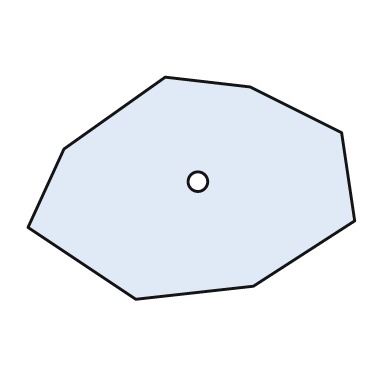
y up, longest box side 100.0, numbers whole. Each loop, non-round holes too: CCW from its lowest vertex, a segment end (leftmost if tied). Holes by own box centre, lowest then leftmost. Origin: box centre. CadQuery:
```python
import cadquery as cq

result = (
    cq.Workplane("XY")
    .moveTo(-17.0, -34.0)
    .lineTo(19.0, -30.0)
    .lineTo(50.0, -10.0)
    .lineTo(46.0, 17.0)
    .lineTo(18.0, 31.0)
    .lineTo(-8.0, 34.0)
    .lineTo(-39.0, 12.0)
    .lineTo(-50.0, -12.0)
    .close()
    .moveTo(2.0, 2.0)
    .circle(3.0)
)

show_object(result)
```